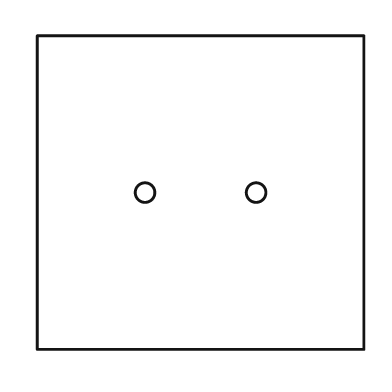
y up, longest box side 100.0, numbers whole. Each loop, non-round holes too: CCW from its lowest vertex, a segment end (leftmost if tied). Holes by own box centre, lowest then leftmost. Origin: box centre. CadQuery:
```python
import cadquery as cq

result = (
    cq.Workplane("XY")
    .moveTo(-50.0, -48.0)
    .lineTo(50.0, -48.0)
    .lineTo(50.0, 48.0)
    .lineTo(-50.0, 48.0)
    .close()
    .moveTo(-17.0, 0.0)
    .circle(3.0)
    .moveTo(17.0, 0.0)
    .circle(3.0)
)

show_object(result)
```